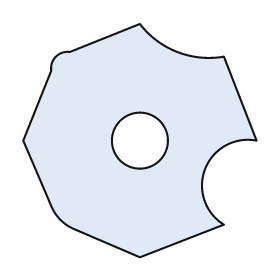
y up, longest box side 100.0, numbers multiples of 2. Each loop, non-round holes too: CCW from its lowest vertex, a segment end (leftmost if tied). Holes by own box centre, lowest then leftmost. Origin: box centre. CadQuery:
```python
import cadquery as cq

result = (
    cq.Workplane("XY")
    .moveTo(0.0, -50.0)
    .lineTo(36.0, -36.0)
    .threePointArc((28.0, -12.0), (50.0, 0.0))
    .lineTo(36.0, 36.0)
    .threePointArc((16.0, 38.0), (0.0, 50.0))
    .lineTo(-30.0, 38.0)
    .threePointArc((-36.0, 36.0), (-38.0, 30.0))
    .lineTo(-50.0, 0.0)
    .lineTo(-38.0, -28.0)
    .threePointArc((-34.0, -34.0), (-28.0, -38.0))
    .close()
    .moveTo(0.0, 0.0)
    .circle(12.0)
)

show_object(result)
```